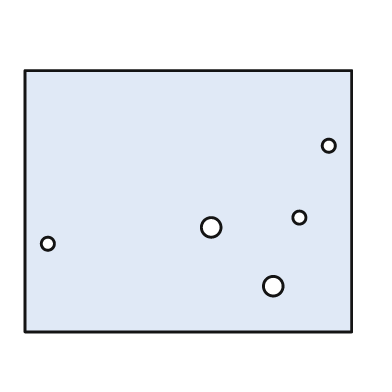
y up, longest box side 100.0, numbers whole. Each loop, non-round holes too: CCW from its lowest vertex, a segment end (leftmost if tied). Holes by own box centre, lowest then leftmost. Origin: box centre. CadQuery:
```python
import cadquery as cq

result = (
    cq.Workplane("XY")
    .moveTo(-50.0, -40.0)
    .lineTo(50.0, -40.0)
    .lineTo(50.0, 40.0)
    .lineTo(-50.0, 40.0)
    .close()
    .moveTo(26.0, -26.0)
    .circle(3.0)
    .moveTo(-43.0, -13.0)
    .circle(2.0)
    .moveTo(7.0, -8.0)
    .circle(3.0)
    .moveTo(34.0, -5.0)
    .circle(2.0)
    .moveTo(43.0, 17.0)
    .circle(2.0)
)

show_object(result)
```